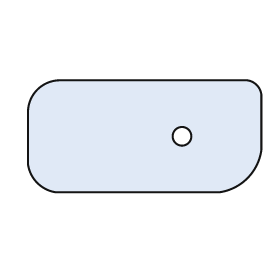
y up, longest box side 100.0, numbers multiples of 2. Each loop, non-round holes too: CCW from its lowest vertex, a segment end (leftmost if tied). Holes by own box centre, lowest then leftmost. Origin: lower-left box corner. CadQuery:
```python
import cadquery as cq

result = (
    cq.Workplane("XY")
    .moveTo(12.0, 0.0)
    .lineTo(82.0, 0.0)
    .threePointArc((94.0, 6.0), (100.0, 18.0))
    .lineTo(100.0, 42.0)
    .threePointArc((98.0, 46.0), (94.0, 48.0))
    .lineTo(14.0, 48.0)
    .threePointArc((4.0, 44.0), (0.0, 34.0))
    .lineTo(0.0, 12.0)
    .threePointArc((4.0, 4.0), (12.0, 0.0))
    .close()
    .moveTo(66.0, 24.0)
    .circle(4.0)
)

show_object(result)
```